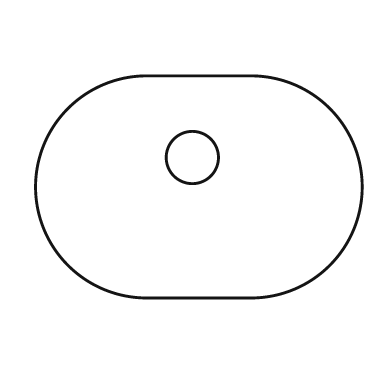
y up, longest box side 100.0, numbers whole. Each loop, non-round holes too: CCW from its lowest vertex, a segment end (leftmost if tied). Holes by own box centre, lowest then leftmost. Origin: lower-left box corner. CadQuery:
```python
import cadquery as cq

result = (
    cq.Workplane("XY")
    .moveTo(34.0, 0.0)
    .lineTo(66.0, 0.0)
    .threePointArc((100.0, 34.0), (66.0, 68.0))
    .lineTo(34.0, 68.0)
    .threePointArc((0.0, 34.0), (34.0, 0.0))
    .close()
    .moveTo(48.0, 43.0)
    .circle(8.0)
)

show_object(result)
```